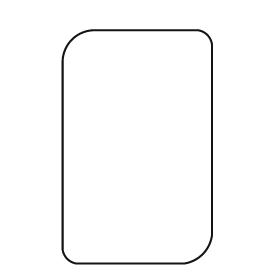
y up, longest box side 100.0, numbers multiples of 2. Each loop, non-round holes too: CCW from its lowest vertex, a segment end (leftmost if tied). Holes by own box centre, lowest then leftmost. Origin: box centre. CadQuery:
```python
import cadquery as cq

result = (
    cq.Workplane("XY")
    .moveTo(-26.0, -50.0)
    .lineTo(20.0, -50.0)
    .threePointArc((28.0, -46.0), (32.0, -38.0))
    .lineTo(32.0, 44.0)
    .threePointArc((30.0, 48.0), (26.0, 50.0))
    .lineTo(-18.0, 50.0)
    .threePointArc((-28.0, 46.0), (-32.0, 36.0))
    .lineTo(-32.0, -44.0)
    .threePointArc((-30.0, -48.0), (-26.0, -50.0))
    .close()
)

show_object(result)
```